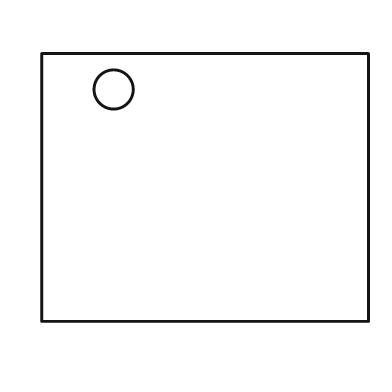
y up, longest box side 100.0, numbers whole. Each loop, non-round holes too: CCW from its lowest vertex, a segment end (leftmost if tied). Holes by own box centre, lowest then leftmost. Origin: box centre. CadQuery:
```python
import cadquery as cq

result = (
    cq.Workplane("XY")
    .moveTo(-50.0, -41.0)
    .lineTo(50.0, -41.0)
    .lineTo(50.0, 41.0)
    .lineTo(-50.0, 41.0)
    .close()
    .moveTo(-28.0, 30.0)
    .circle(6.0)
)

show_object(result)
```